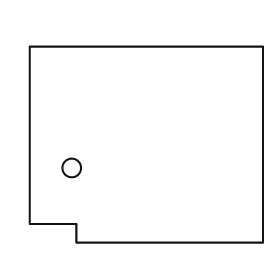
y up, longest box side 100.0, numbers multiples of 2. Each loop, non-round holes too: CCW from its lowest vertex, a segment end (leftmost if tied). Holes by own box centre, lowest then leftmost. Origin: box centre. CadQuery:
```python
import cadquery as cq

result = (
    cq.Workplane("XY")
    .moveTo(-30.0, -42.0)
    .lineTo(50.0, -42.0)
    .lineTo(50.0, 42.0)
    .lineTo(-50.0, 42.0)
    .lineTo(-50.0, -34.0)
    .lineTo(-30.0, -34.0)
    .close()
    .moveTo(-32.0, -10.0)
    .circle(4.0)
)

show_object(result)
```